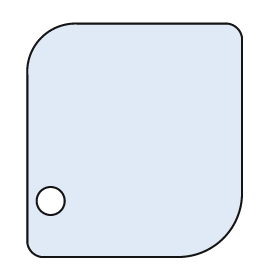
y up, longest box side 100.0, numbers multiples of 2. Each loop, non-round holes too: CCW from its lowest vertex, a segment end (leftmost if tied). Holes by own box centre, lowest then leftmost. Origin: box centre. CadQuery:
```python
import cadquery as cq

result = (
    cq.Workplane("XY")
    .moveTo(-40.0, -50.0)
    .lineTo(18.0, -50.0)
    .threePointArc((38.0, -42.0), (46.0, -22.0))
    .lineTo(46.0, 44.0)
    .threePointArc((44.0, 48.0), (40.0, 50.0))
    .lineTo(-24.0, 50.0)
    .threePointArc((-40.0, 44.0), (-46.0, 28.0))
    .lineTo(-46.0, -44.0)
    .threePointArc((-44.0, -48.0), (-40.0, -50.0))
    .close()
    .moveTo(-36.0, -26.0)
    .circle(6.0)
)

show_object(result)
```